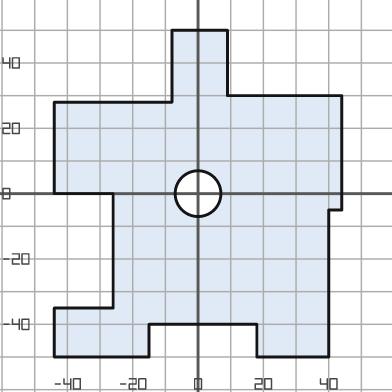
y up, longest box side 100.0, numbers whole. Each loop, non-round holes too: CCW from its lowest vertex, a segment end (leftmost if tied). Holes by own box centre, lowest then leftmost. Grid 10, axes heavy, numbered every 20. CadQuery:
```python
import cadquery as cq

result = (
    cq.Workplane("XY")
    .moveTo(-44.0, -50.0)
    .lineTo(-15.0, -50.0)
    .lineTo(-15.0, -40.0)
    .lineTo(18.0, -40.0)
    .lineTo(18.0, -50.0)
    .lineTo(40.0, -50.0)
    .lineTo(40.0, -5.0)
    .lineTo(44.0, -5.0)
    .lineTo(44.0, 30.0)
    .lineTo(9.0, 30.0)
    .lineTo(9.0, 50.0)
    .lineTo(-8.0, 50.0)
    .lineTo(-8.0, 28.0)
    .lineTo(-44.0, 28.0)
    .lineTo(-44.0, 0.0)
    .lineTo(-26.0, 0.0)
    .lineTo(-26.0, -35.0)
    .lineTo(-44.0, -35.0)
    .close()
    .moveTo(0.0, 0.0)
    .circle(7.0)
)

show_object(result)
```